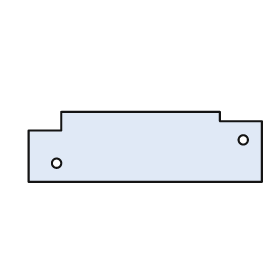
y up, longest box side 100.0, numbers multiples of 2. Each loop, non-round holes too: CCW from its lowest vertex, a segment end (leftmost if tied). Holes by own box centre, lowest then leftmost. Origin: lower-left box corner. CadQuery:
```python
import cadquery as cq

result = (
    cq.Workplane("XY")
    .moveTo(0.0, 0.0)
    .lineTo(100.0, 0.0)
    .lineTo(100.0, 26.0)
    .lineTo(82.0, 26.0)
    .lineTo(82.0, 30.0)
    .lineTo(14.0, 30.0)
    .lineTo(14.0, 22.0)
    .lineTo(0.0, 22.0)
    .close()
    .moveTo(12.0, 8.0)
    .circle(2.0)
    .moveTo(92.0, 18.0)
    .circle(2.0)
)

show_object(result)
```